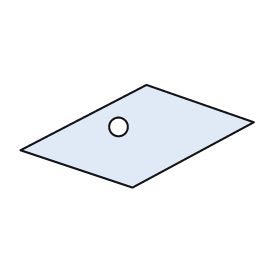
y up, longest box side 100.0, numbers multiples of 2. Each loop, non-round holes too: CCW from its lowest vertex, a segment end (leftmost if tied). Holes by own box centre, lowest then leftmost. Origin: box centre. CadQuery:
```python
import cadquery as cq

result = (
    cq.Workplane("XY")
    .moveTo(-2.0, -22.0)
    .lineTo(50.0, 6.0)
    .lineTo(4.0, 22.0)
    .lineTo(-50.0, -6.0)
    .close()
    .moveTo(-8.0, 4.0)
    .circle(4.0)
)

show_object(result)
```